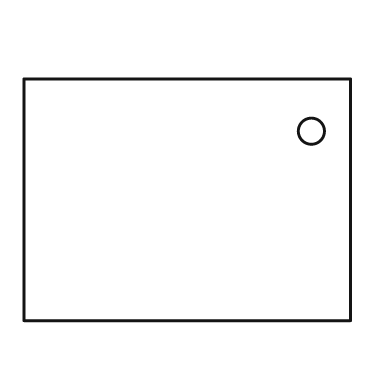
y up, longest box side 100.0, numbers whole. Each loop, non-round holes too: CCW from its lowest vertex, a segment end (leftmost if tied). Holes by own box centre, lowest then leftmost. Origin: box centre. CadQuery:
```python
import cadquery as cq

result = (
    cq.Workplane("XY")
    .moveTo(-50.0, -37.0)
    .lineTo(50.0, -37.0)
    .lineTo(50.0, 37.0)
    .lineTo(-50.0, 37.0)
    .close()
    .moveTo(38.0, 21.0)
    .circle(4.0)
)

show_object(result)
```